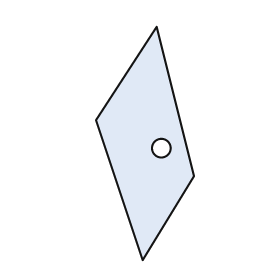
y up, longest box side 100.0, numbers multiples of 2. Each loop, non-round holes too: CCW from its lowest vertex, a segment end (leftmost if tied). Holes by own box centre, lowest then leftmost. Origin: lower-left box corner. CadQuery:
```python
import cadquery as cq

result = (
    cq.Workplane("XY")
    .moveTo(20.0, 0.0)
    .lineTo(42.0, 36.0)
    .lineTo(26.0, 100.0)
    .lineTo(0.0, 60.0)
    .close()
    .moveTo(28.0, 48.0)
    .circle(4.0)
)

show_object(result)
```